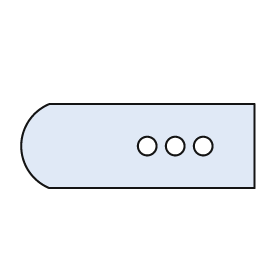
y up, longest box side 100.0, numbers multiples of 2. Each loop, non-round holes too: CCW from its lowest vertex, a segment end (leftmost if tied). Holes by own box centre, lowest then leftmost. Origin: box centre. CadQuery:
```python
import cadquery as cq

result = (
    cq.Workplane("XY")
    .moveTo(-38.0, -18.0)
    .lineTo(50.0, -18.0)
    .lineTo(50.0, 18.0)
    .lineTo(-38.0, 18.0)
    .threePointArc((-50.0, 0.0), (-38.0, -18.0))
    .close()
    .moveTo(4.0, 0.0)
    .circle(4.0)
    .moveTo(16.0, 0.0)
    .circle(4.0)
    .moveTo(28.0, 0.0)
    .circle(4.0)
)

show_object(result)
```